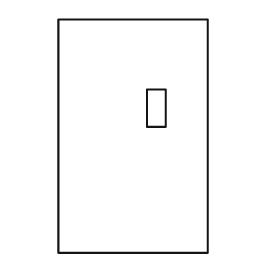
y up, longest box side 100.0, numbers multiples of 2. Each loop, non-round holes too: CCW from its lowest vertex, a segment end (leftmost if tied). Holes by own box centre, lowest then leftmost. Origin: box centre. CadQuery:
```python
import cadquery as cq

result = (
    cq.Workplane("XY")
    .moveTo(-32.0, -50.0)
    .lineTo(32.0, -50.0)
    .lineTo(32.0, 50.0)
    .lineTo(-32.0, 50.0)
    .close()
    .moveTo(6.0, 4.0)
    .lineTo(14.0, 4.0)
    .lineTo(14.0, 20.0)
    .lineTo(6.0, 20.0)
    .close()
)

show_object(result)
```